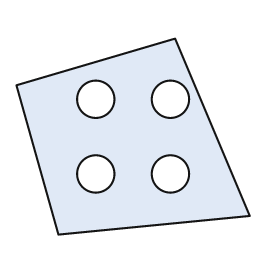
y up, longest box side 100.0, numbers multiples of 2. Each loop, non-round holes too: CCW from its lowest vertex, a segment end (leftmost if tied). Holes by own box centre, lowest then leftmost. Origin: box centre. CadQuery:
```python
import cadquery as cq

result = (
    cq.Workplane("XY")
    .moveTo(-32.0, -42.0)
    .lineTo(50.0, -34.0)
    .lineTo(18.0, 42.0)
    .lineTo(-50.0, 22.0)
    .close()
    .moveTo(-16.0, -16.0)
    .circle(8.0)
    .moveTo(16.0, -16.0)
    .circle(8.0)
    .moveTo(-16.0, 16.0)
    .circle(8.0)
    .moveTo(16.0, 16.0)
    .circle(8.0)
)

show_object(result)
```